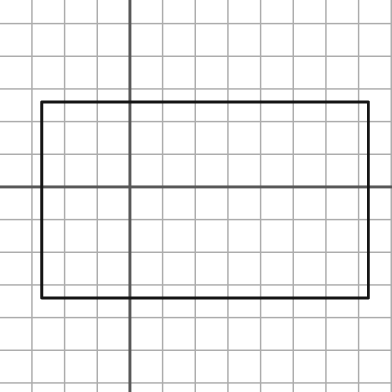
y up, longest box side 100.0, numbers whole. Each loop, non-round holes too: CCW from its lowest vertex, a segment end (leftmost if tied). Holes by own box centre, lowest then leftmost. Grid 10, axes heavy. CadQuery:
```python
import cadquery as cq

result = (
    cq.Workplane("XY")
    .moveTo(-27.0, -34.0)
    .lineTo(73.0, -34.0)
    .lineTo(73.0, 26.0)
    .lineTo(-27.0, 26.0)
    .close()
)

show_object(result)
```